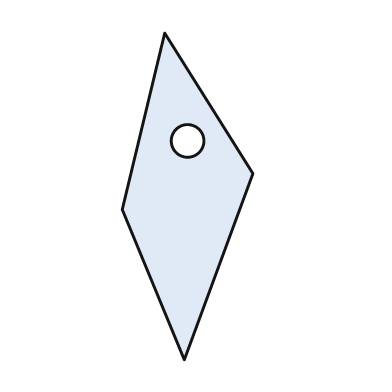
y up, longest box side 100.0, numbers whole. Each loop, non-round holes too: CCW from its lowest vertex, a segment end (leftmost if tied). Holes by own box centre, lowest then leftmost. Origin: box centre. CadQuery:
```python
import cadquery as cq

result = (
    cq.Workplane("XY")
    .moveTo(-1.0, -50.0)
    .lineTo(20.0, 7.0)
    .lineTo(-7.0, 50.0)
    .lineTo(-20.0, -4.0)
    .close()
    .moveTo(0.0, 17.0)
    .circle(5.0)
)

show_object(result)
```